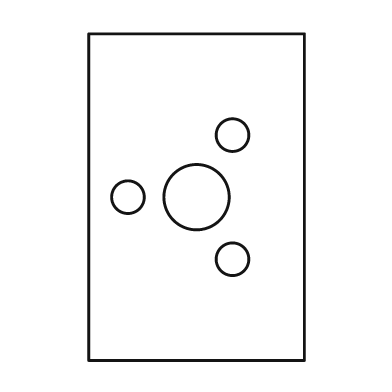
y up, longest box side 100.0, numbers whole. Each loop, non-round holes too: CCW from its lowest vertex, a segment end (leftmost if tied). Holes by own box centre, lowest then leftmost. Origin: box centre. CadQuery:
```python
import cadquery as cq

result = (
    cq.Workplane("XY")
    .moveTo(-33.0, -50.0)
    .lineTo(33.0, -50.0)
    .lineTo(33.0, 50.0)
    .lineTo(-33.0, 50.0)
    .close()
    .moveTo(11.0, -19.0)
    .circle(5.0)
    .moveTo(-21.0, 0.0)
    .circle(5.0)
    .moveTo(0.0, 0.0)
    .circle(10.0)
    .moveTo(11.0, 19.0)
    .circle(5.0)
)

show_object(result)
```